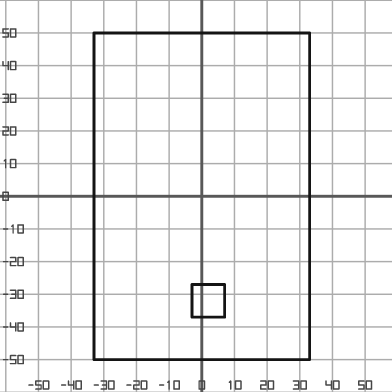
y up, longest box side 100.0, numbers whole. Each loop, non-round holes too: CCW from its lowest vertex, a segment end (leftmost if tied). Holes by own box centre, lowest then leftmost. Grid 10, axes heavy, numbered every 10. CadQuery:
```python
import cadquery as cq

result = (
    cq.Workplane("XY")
    .moveTo(-33.0, -50.0)
    .lineTo(33.0, -50.0)
    .lineTo(33.0, 50.0)
    .lineTo(-33.0, 50.0)
    .close()
    .moveTo(-3.0, -37.0)
    .lineTo(7.0, -37.0)
    .lineTo(7.0, -27.0)
    .lineTo(-3.0, -27.0)
    .close()
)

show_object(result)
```